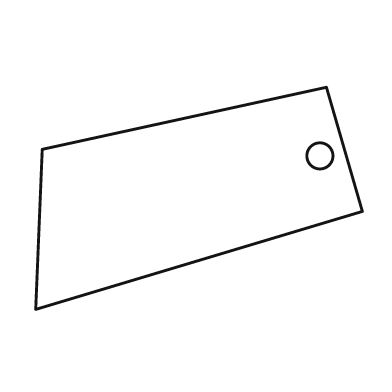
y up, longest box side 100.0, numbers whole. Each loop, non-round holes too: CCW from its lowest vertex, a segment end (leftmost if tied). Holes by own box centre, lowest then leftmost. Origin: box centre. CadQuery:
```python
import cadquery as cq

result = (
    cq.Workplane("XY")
    .moveTo(-50.0, -34.0)
    .lineTo(50.0, -4.0)
    .lineTo(39.0, 34.0)
    .lineTo(-48.0, 15.0)
    .close()
    .moveTo(37.0, 13.0)
    .circle(4.0)
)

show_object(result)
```